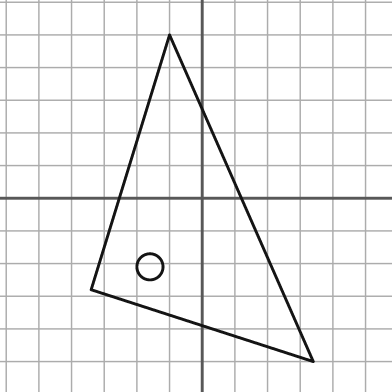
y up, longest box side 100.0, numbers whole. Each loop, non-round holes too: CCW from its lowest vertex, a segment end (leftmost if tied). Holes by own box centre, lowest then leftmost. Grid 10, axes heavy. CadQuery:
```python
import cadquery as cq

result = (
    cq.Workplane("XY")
    .moveTo(34.0, -50.0)
    .lineTo(-10.0, 50.0)
    .lineTo(-34.0, -28.0)
    .close()
    .moveTo(-16.0, -21.0)
    .circle(4.0)
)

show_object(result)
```